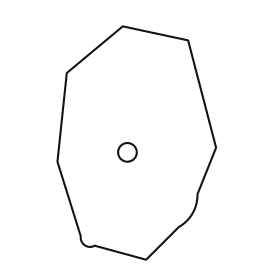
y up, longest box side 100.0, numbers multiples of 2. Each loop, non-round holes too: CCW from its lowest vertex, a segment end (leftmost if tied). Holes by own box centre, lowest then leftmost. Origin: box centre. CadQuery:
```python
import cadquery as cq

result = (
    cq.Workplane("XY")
    .moveTo(4.0, -50.0)
    .lineTo(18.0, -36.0)
    .threePointArc((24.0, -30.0), (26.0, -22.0))
    .lineTo(34.0, -2.0)
    .lineTo(22.0, 44.0)
    .lineTo(-6.0, 50.0)
    .lineTo(-30.0, 30.0)
    .lineTo(-34.0, -8.0)
    .lineTo(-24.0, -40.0)
    .threePointArc((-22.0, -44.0), (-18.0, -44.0))
    .close()
    .moveTo(-4.0, -4.0)
    .circle(4.0)
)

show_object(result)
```